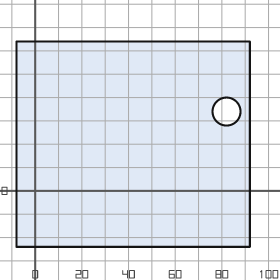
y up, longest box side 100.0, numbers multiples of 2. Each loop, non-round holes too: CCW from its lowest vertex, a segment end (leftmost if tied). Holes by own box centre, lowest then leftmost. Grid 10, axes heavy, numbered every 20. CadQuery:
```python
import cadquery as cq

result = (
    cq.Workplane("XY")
    .moveTo(-8.0, -24.0)
    .lineTo(92.0, -24.0)
    .lineTo(92.0, 64.0)
    .lineTo(-8.0, 64.0)
    .close()
    .moveTo(82.0, 34.0)
    .circle(6.0)
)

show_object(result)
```